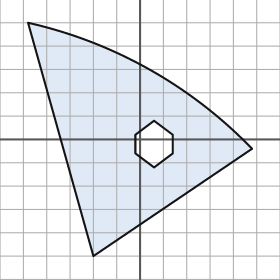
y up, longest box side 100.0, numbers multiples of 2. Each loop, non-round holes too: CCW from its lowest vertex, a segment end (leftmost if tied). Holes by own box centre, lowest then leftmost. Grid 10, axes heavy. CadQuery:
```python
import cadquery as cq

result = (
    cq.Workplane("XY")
    .moveTo(-20.0, -50.0)
    .lineTo(48.0, -4.0)
    .threePointArc((4.0, 30.0), (-48.0, 50.0))
    .close()
    .moveTo(6.0, -12.0)
    .lineTo(14.0, -6.0)
    .lineTo(14.0, 2.0)
    .lineTo(6.0, 8.0)
    .lineTo(-2.0, 2.0)
    .lineTo(-2.0, -6.0)
    .close()
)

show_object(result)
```